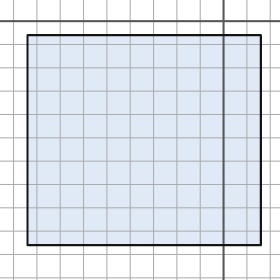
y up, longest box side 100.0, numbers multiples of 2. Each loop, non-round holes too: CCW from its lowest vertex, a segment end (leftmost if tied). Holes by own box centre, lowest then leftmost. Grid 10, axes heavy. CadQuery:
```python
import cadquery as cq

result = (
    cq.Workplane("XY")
    .moveTo(-84.0, -96.0)
    .lineTo(16.0, -96.0)
    .lineTo(16.0, -6.0)
    .lineTo(-84.0, -6.0)
    .close()
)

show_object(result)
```